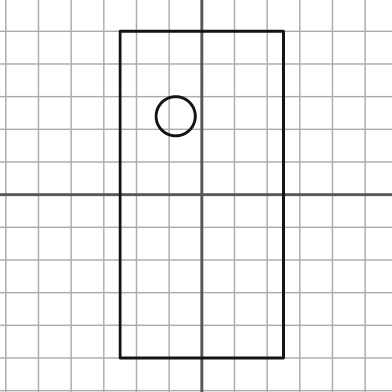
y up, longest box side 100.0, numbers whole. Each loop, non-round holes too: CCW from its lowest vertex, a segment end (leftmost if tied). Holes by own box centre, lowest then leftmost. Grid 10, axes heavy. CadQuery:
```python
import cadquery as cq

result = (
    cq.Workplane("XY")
    .moveTo(-25.0, -50.0)
    .lineTo(25.0, -50.0)
    .lineTo(25.0, 50.0)
    .lineTo(-25.0, 50.0)
    .close()
    .moveTo(-8.0, 24.0)
    .circle(6.0)
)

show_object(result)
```